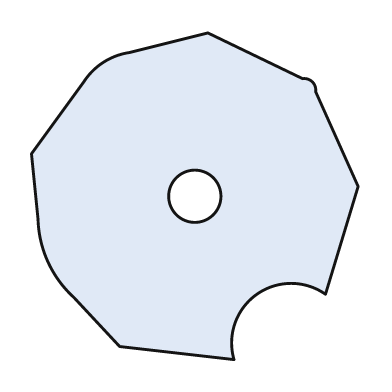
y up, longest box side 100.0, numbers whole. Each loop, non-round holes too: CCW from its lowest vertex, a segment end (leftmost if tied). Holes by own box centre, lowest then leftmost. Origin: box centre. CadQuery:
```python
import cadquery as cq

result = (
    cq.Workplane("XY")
    .moveTo(12.0, -50.0)
    .threePointArc((19.0, -30.0), (40.0, -30.0))
    .lineTo(50.0, 3.0)
    .lineTo(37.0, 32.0)
    .threePointArc((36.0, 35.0), (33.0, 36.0))
    .lineTo(4.0, 50.0)
    .lineTo(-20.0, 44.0)
    .threePointArc((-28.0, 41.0), (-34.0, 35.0))
    .lineTo(-50.0, 13.0)
    .lineTo(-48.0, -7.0)
    .threePointArc((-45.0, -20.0), (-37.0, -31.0))
    .lineTo(-23.0, -46.0)
    .close()
    .moveTo(0.0, 0.0)
    .circle(8.0)
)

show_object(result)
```